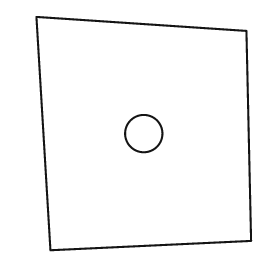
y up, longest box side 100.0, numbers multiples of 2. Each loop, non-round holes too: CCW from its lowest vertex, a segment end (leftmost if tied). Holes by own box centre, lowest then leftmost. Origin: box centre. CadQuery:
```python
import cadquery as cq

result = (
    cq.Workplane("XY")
    .moveTo(-40.0, -50.0)
    .lineTo(46.0, -46.0)
    .lineTo(44.0, 44.0)
    .lineTo(-46.0, 50.0)
    .close()
    .moveTo(0.0, 0.0)
    .circle(8.0)
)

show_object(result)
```